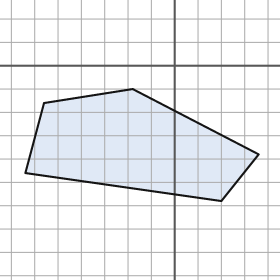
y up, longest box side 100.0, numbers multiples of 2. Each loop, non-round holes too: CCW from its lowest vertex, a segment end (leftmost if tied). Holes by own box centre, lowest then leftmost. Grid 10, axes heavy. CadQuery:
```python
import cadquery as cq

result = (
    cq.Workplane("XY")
    .moveTo(20.0, -58.0)
    .lineTo(36.0, -38.0)
    .lineTo(-18.0, -10.0)
    .lineTo(-56.0, -16.0)
    .lineTo(-64.0, -46.0)
    .close()
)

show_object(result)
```